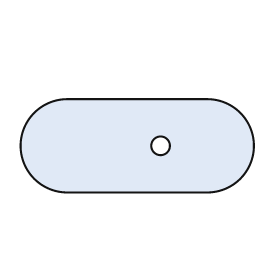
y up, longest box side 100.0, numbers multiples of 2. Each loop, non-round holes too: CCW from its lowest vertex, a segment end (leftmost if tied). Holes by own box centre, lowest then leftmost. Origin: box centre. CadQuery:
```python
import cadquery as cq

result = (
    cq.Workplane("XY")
    .moveTo(-30.0, -20.0)
    .lineTo(30.0, -20.0)
    .threePointArc((50.0, 0.0), (30.0, 20.0))
    .lineTo(-30.0, 20.0)
    .threePointArc((-50.0, 0.0), (-30.0, -20.0))
    .close()
    .moveTo(10.0, 0.0)
    .circle(4.0)
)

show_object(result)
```